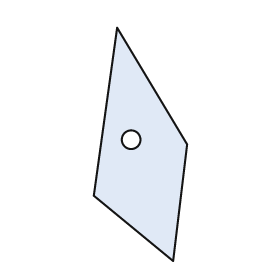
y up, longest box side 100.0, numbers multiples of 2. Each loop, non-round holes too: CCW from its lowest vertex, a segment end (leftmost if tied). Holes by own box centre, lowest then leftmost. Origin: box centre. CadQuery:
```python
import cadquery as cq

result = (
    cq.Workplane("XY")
    .moveTo(14.0, -50.0)
    .lineTo(20.0, 0.0)
    .lineTo(-10.0, 50.0)
    .lineTo(-20.0, -22.0)
    .close()
    .moveTo(-4.0, 2.0)
    .circle(4.0)
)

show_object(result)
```